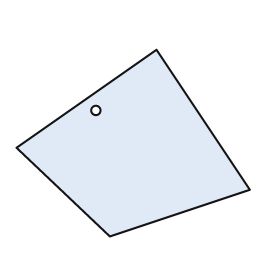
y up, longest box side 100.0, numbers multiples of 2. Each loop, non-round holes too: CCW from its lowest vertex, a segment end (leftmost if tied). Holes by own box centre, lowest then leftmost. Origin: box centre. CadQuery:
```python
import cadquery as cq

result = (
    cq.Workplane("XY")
    .moveTo(-10.0, -40.0)
    .lineTo(50.0, -20.0)
    .lineTo(10.0, 40.0)
    .lineTo(-50.0, -2.0)
    .close()
    .moveTo(-16.0, 14.0)
    .circle(2.0)
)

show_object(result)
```